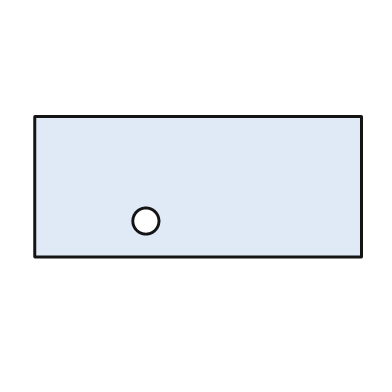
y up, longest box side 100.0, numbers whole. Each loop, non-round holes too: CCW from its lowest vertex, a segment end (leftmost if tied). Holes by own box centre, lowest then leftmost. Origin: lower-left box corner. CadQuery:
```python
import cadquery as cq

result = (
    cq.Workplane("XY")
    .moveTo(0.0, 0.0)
    .lineTo(100.0, 0.0)
    .lineTo(100.0, 43.0)
    .lineTo(0.0, 43.0)
    .close()
    .moveTo(34.0, 11.0)
    .circle(4.0)
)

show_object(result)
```